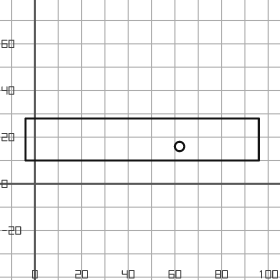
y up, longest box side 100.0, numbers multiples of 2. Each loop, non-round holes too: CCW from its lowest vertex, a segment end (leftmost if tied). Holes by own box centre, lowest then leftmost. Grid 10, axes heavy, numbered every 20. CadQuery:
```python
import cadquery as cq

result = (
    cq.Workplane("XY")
    .moveTo(-4.0, 10.0)
    .lineTo(96.0, 10.0)
    .lineTo(96.0, 28.0)
    .lineTo(-4.0, 28.0)
    .close()
    .moveTo(62.0, 16.0)
    .circle(2.0)
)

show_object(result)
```